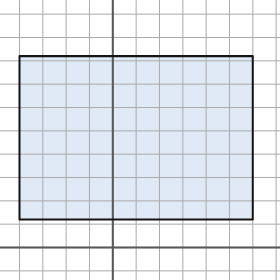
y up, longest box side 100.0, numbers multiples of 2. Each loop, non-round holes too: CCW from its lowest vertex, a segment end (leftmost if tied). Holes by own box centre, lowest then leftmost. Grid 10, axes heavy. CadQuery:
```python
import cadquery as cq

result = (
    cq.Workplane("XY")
    .moveTo(-40.0, 12.0)
    .lineTo(60.0, 12.0)
    .lineTo(60.0, 82.0)
    .lineTo(-40.0, 82.0)
    .close()
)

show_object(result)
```